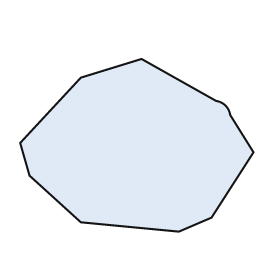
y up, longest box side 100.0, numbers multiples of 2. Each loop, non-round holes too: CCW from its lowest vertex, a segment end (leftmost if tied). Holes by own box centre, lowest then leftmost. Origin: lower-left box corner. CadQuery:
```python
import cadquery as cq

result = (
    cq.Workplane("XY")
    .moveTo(68.0, 0.0)
    .lineTo(82.0, 6.0)
    .lineTo(100.0, 34.0)
    .lineTo(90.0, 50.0)
    .threePointArc((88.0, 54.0), (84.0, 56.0))
    .lineTo(52.0, 74.0)
    .lineTo(26.0, 66.0)
    .lineTo(0.0, 38.0)
    .lineTo(4.0, 24.0)
    .lineTo(26.0, 4.0)
    .close()
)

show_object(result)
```